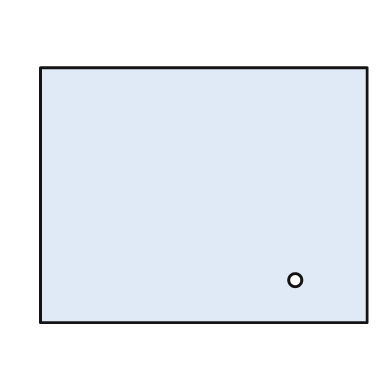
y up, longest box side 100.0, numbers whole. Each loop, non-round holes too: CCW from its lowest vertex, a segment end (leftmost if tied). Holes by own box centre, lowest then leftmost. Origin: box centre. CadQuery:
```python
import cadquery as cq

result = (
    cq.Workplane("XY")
    .moveTo(-50.0, -39.0)
    .lineTo(50.0, -39.0)
    .lineTo(50.0, 39.0)
    .lineTo(-50.0, 39.0)
    .close()
    .moveTo(28.0, -26.0)
    .circle(2.0)
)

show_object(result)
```